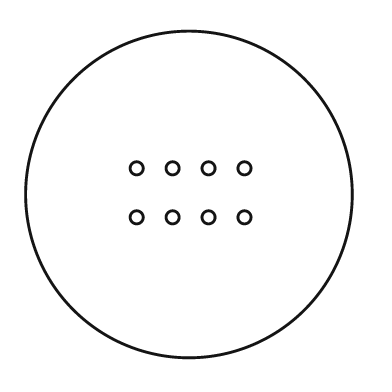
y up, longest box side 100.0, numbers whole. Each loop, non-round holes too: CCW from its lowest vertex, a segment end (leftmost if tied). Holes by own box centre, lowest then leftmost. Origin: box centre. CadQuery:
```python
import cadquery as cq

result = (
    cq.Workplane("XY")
    .moveTo(0.0, 0.0)
    .circle(50.0)
    .moveTo(-16.0, -7.0)
    .circle(2.0)
    .moveTo(-5.0, -7.0)
    .circle(2.0)
    .moveTo(6.0, -7.0)
    .circle(2.0)
    .moveTo(17.0, -7.0)
    .circle(2.0)
    .moveTo(-16.0, 8.0)
    .circle(2.0)
    .moveTo(-5.0, 8.0)
    .circle(2.0)
    .moveTo(6.0, 8.0)
    .circle(2.0)
    .moveTo(17.0, 8.0)
    .circle(2.0)
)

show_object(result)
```